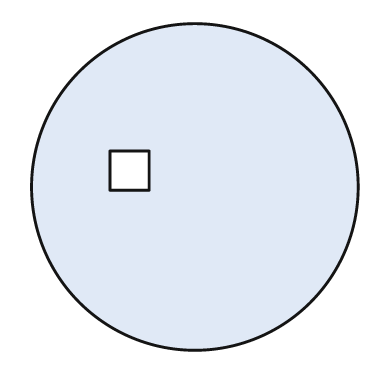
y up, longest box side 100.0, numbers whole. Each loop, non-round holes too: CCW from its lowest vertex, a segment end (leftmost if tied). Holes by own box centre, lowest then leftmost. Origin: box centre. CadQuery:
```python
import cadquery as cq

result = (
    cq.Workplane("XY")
    .moveTo(0.0, 0.0)
    .circle(50.0)
    .moveTo(-26.0, -1.0)
    .lineTo(-14.0, -1.0)
    .lineTo(-14.0, 11.0)
    .lineTo(-26.0, 11.0)
    .close()
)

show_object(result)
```